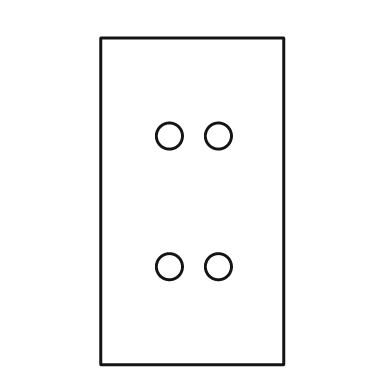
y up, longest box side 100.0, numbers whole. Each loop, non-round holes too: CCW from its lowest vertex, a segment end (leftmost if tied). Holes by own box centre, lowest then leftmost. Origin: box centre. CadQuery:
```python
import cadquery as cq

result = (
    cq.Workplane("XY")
    .moveTo(-28.0, -50.0)
    .lineTo(28.0, -50.0)
    .lineTo(28.0, 50.0)
    .lineTo(-28.0, 50.0)
    .close()
    .moveTo(-7.0, -20.0)
    .circle(4.0)
    .moveTo(8.0, -20.0)
    .circle(4.0)
    .moveTo(-7.0, 20.0)
    .circle(4.0)
    .moveTo(8.0, 20.0)
    .circle(4.0)
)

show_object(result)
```